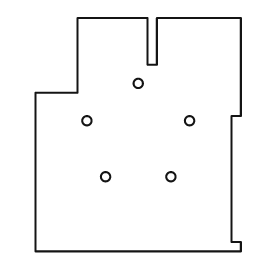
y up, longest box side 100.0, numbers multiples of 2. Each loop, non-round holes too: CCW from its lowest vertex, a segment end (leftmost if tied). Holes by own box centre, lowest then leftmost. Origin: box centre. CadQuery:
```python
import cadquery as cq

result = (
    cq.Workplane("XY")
    .moveTo(-44.0, -50.0)
    .lineTo(44.0, -50.0)
    .lineTo(44.0, -46.0)
    .lineTo(40.0, -46.0)
    .lineTo(40.0, 8.0)
    .lineTo(44.0, 8.0)
    .lineTo(44.0, 50.0)
    .lineTo(8.0, 50.0)
    .lineTo(8.0, 30.0)
    .lineTo(4.0, 30.0)
    .lineTo(4.0, 50.0)
    .lineTo(-26.0, 50.0)
    .lineTo(-26.0, 18.0)
    .lineTo(-44.0, 18.0)
    .close()
    .moveTo(-14.0, -18.0)
    .circle(2.0)
    .moveTo(14.0, -18.0)
    .circle(2.0)
    .moveTo(-22.0, 6.0)
    .circle(2.0)
    .moveTo(22.0, 6.0)
    .circle(2.0)
    .moveTo(0.0, 22.0)
    .circle(2.0)
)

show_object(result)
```